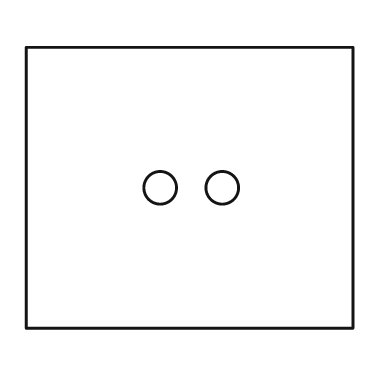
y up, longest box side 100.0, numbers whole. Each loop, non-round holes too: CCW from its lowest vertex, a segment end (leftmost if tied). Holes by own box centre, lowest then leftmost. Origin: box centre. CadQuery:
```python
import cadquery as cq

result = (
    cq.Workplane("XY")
    .moveTo(-50.0, -43.0)
    .lineTo(50.0, -43.0)
    .lineTo(50.0, 43.0)
    .lineTo(-50.0, 43.0)
    .close()
    .moveTo(-9.0, 0.0)
    .circle(5.0)
    .moveTo(10.0, 0.0)
    .circle(5.0)
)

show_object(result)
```